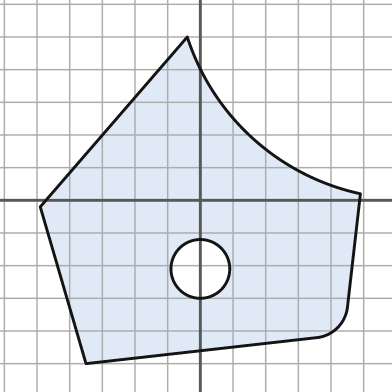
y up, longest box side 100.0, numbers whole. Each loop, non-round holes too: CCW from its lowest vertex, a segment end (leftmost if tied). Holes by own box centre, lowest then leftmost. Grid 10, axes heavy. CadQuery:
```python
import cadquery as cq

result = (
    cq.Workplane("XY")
    .moveTo(-35.0, -50.0)
    .lineTo(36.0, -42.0)
    .threePointArc((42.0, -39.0), (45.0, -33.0))
    .lineTo(49.0, 2.0)
    .threePointArc((16.0, 19.0), (-4.0, 50.0))
    .lineTo(-49.0, -2.0)
    .close()
    .moveTo(0.0, -21.0)
    .circle(9.0)
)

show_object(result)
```